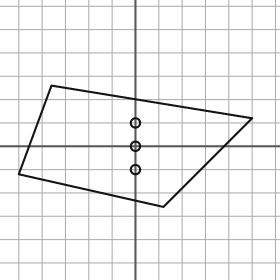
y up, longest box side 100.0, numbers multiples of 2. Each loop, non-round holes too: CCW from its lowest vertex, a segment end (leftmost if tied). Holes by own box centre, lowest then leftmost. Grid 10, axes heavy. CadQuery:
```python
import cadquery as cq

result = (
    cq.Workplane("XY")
    .moveTo(12.0, -26.0)
    .lineTo(50.0, 12.0)
    .lineTo(-36.0, 26.0)
    .lineTo(-50.0, -12.0)
    .close()
    .moveTo(0.0, -10.0)
    .circle(2.0)
    .moveTo(0.0, 0.0)
    .circle(2.0)
    .moveTo(0.0, 10.0)
    .circle(2.0)
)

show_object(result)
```